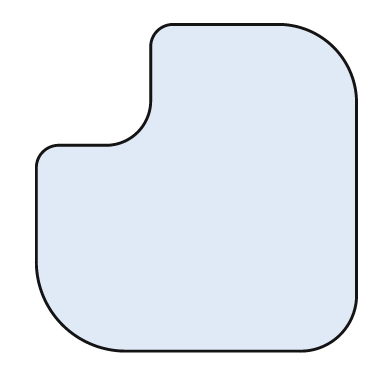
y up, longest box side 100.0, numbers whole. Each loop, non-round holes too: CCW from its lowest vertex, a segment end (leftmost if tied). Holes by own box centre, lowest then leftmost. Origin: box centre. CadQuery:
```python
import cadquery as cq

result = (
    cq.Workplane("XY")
    .moveTo(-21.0, -50.0)
    .lineTo(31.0, -50.0)
    .threePointArc((44.0, -45.0), (49.0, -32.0))
    .lineTo(49.0, 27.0)
    .threePointArc((42.0, 43.0), (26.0, 50.0))
    .lineTo(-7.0, 50.0)
    .threePointArc((-12.0, 48.0), (-14.0, 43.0))
    .lineTo(-14.0, 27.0)
    .threePointArc((-18.0, 17.0), (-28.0, 13.0))
    .lineTo(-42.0, 13.0)
    .threePointArc((-47.0, 11.0), (-49.0, 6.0))
    .lineTo(-49.0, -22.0)
    .threePointArc((-41.0, -42.0), (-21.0, -50.0))
    .close()
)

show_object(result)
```